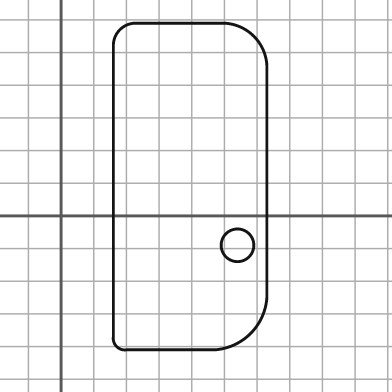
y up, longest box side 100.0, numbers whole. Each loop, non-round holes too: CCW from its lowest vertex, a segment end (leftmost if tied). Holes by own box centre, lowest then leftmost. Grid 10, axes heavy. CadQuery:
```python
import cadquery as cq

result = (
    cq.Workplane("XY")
    .moveTo(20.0, -41.0)
    .lineTo(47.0, -41.0)
    .threePointArc((58.0, -36.0), (63.0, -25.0))
    .lineTo(63.0, 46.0)
    .threePointArc((59.0, 55.0), (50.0, 59.0))
    .lineTo(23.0, 59.0)
    .threePointArc((18.0, 57.0), (16.0, 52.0))
    .lineTo(16.0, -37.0)
    .threePointArc((17.0, -40.0), (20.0, -41.0))
    .close()
    .moveTo(54.0, -9.0)
    .circle(5.0)
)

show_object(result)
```